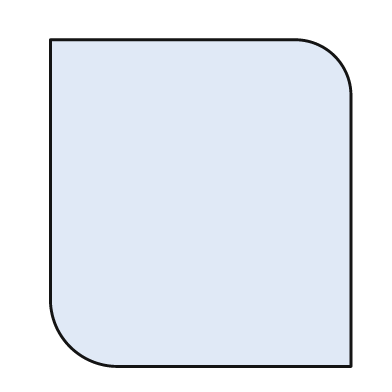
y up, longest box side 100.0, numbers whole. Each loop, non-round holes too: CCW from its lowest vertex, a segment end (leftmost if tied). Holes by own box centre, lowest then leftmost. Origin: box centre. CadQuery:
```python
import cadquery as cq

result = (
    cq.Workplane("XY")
    .moveTo(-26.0, -50.0)
    .lineTo(46.0, -50.0)
    .lineTo(46.0, 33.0)
    .threePointArc((41.0, 45.0), (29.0, 50.0))
    .lineTo(-46.0, 50.0)
    .lineTo(-46.0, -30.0)
    .threePointArc((-40.0, -44.0), (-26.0, -50.0))
    .close()
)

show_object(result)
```